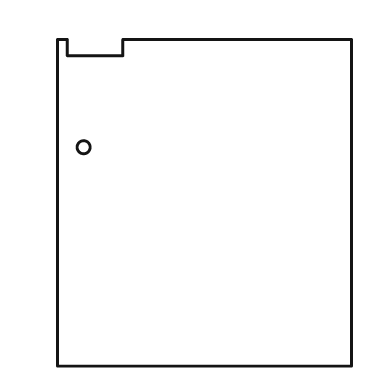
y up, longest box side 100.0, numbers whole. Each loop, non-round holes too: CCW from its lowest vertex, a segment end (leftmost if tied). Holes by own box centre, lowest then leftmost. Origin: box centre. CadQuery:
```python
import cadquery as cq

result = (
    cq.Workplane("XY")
    .moveTo(-45.0, -50.0)
    .lineTo(45.0, -50.0)
    .lineTo(45.0, 50.0)
    .lineTo(-25.0, 50.0)
    .lineTo(-25.0, 45.0)
    .lineTo(-42.0, 45.0)
    .lineTo(-42.0, 50.0)
    .lineTo(-45.0, 50.0)
    .close()
    .moveTo(-37.0, 17.0)
    .circle(2.0)
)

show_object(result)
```